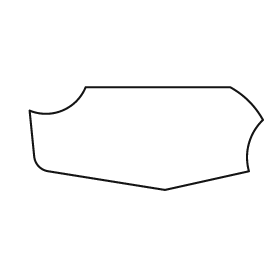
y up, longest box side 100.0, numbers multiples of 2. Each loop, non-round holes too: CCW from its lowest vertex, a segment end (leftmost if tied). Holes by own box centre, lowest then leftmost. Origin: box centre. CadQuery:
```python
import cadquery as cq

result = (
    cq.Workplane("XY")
    .moveTo(8.0, -22.0)
    .lineTo(44.0, -14.0)
    .threePointArc((44.0, -2.0), (50.0, 8.0))
    .threePointArc((44.0, 16.0), (36.0, 22.0))
    .lineTo(-26.0, 22.0)
    .threePointArc((-36.0, 12.0), (-50.0, 12.0))
    .lineTo(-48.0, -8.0)
    .threePointArc((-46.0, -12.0), (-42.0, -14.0))
    .close()
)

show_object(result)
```